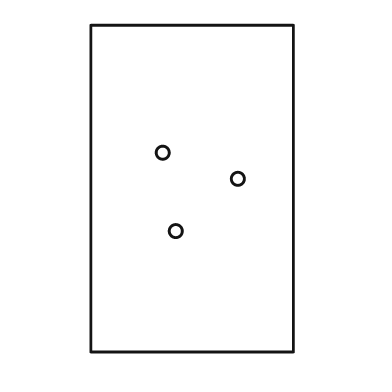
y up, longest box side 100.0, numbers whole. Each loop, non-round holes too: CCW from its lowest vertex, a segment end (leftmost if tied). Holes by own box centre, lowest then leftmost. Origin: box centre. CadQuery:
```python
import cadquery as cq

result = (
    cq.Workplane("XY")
    .moveTo(-31.0, -50.0)
    .lineTo(31.0, -50.0)
    .lineTo(31.0, 50.0)
    .lineTo(-31.0, 50.0)
    .close()
    .moveTo(-5.0, -13.0)
    .circle(2.0)
    .moveTo(14.0, 3.0)
    .circle(2.0)
    .moveTo(-9.0, 11.0)
    .circle(2.0)
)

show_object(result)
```